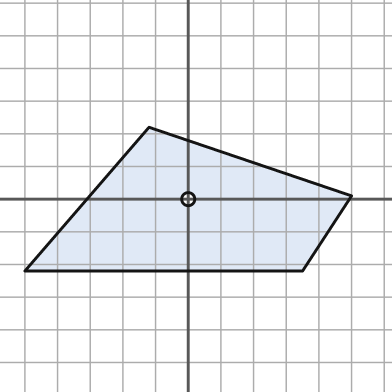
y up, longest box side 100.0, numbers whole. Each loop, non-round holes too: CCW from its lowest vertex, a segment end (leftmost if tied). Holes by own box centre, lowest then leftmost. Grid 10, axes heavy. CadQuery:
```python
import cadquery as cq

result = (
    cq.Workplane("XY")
    .moveTo(-50.0, -22.0)
    .lineTo(35.0, -22.0)
    .lineTo(50.0, 1.0)
    .lineTo(-12.0, 22.0)
    .close()
    .moveTo(0.0, 0.0)
    .circle(2.0)
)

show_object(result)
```